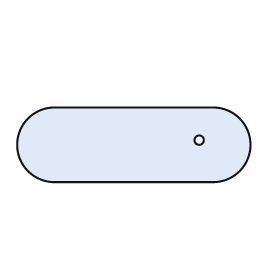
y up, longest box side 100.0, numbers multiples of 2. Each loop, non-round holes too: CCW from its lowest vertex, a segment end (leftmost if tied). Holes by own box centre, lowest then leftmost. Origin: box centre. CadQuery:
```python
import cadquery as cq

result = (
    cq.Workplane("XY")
    .moveTo(-34.0, -16.0)
    .lineTo(34.0, -16.0)
    .threePointArc((50.0, 0.0), (34.0, 16.0))
    .lineTo(-34.0, 16.0)
    .threePointArc((-50.0, 0.0), (-34.0, -16.0))
    .close()
    .moveTo(28.0, 2.0)
    .circle(2.0)
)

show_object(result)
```